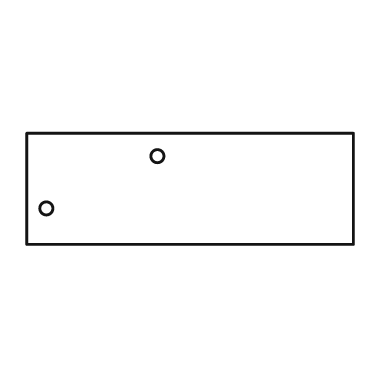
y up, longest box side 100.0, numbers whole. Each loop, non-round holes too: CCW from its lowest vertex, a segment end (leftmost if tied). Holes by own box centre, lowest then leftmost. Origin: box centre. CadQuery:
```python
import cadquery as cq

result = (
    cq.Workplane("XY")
    .moveTo(-50.0, -17.0)
    .lineTo(50.0, -17.0)
    .lineTo(50.0, 17.0)
    .lineTo(-50.0, 17.0)
    .close()
    .moveTo(-44.0, -6.0)
    .circle(2.0)
    .moveTo(-10.0, 10.0)
    .circle(2.0)
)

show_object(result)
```